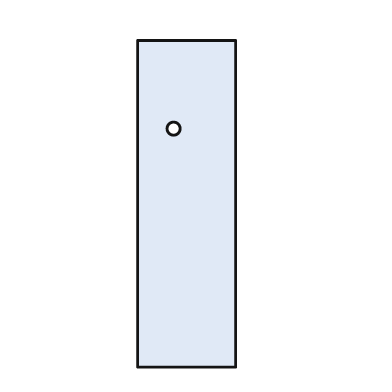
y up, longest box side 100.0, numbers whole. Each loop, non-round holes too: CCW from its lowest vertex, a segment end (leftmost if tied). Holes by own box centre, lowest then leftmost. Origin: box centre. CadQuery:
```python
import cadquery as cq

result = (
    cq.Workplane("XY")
    .moveTo(-15.0, -50.0)
    .lineTo(15.0, -50.0)
    .lineTo(15.0, 50.0)
    .lineTo(-15.0, 50.0)
    .close()
    .moveTo(-4.0, 23.0)
    .circle(2.0)
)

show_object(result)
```